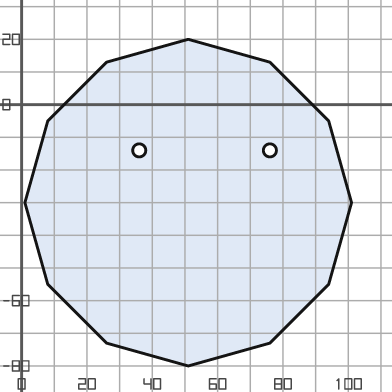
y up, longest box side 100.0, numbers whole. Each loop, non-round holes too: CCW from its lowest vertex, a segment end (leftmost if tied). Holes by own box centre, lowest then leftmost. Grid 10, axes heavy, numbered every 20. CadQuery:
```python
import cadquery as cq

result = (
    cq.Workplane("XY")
    .moveTo(51.0, -80.0)
    .lineTo(76.0, -73.0)
    .lineTo(94.0, -55.0)
    .lineTo(101.0, -30.0)
    .lineTo(94.0, -5.0)
    .lineTo(76.0, 13.0)
    .lineTo(51.0, 20.0)
    .lineTo(26.0, 13.0)
    .lineTo(8.0, -5.0)
    .lineTo(1.0, -30.0)
    .lineTo(8.0, -55.0)
    .lineTo(26.0, -73.0)
    .close()
    .moveTo(36.0, -14.0)
    .circle(2.0)
    .moveTo(76.0, -14.0)
    .circle(2.0)
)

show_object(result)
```